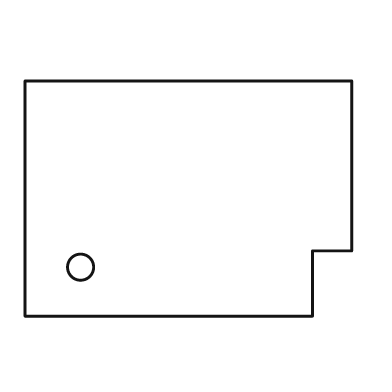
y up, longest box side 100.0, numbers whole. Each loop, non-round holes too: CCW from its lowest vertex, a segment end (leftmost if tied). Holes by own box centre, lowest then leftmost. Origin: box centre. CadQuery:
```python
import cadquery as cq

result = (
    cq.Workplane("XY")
    .moveTo(-50.0, -36.0)
    .lineTo(38.0, -36.0)
    .lineTo(38.0, -16.0)
    .lineTo(50.0, -16.0)
    .lineTo(50.0, 36.0)
    .lineTo(-50.0, 36.0)
    .close()
    .moveTo(-33.0, -21.0)
    .circle(4.0)
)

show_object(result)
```